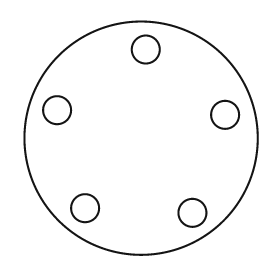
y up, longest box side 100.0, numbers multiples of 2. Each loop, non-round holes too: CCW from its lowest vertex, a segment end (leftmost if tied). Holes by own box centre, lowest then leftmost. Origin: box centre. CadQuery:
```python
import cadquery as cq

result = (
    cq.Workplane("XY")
    .moveTo(0.0, 0.0)
    .circle(50.0)
    .moveTo(22.0, -32.0)
    .circle(6.0)
    .moveTo(-24.0, -30.0)
    .circle(6.0)
    .moveTo(36.0, 10.0)
    .circle(6.0)
    .moveTo(-36.0, 12.0)
    .circle(6.0)
    .moveTo(2.0, 38.0)
    .circle(6.0)
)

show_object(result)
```